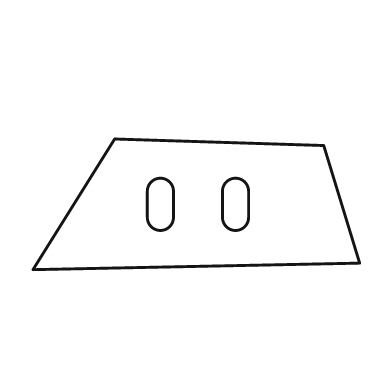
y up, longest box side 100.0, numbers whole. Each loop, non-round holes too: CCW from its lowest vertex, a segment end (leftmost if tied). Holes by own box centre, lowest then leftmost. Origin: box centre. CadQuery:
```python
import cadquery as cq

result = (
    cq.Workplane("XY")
    .moveTo(-50.0, -20.0)
    .lineTo(50.0, -18.0)
    .lineTo(39.0, 18.0)
    .lineTo(-25.0, 20.0)
    .close()
    .moveTo(-15.0, -4.0)
    .threePointArc((-11.0, -8.0), (-7.0, -4.0))
    .lineTo(-7.0, 4.0)
    .threePointArc((-11.0, 8.0), (-15.0, 4.0))
    .close()
    .moveTo(8.0, -4.0)
    .threePointArc((12.0, -8.0), (16.0, -4.0))
    .lineTo(16.0, 4.0)
    .threePointArc((12.0, 8.0), (8.0, 4.0))
    .close()
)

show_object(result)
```